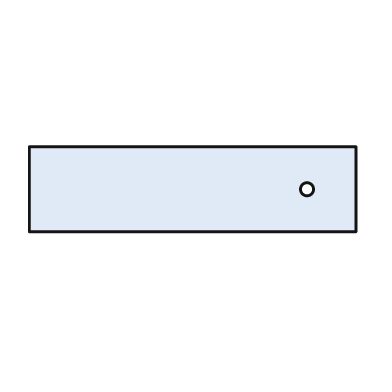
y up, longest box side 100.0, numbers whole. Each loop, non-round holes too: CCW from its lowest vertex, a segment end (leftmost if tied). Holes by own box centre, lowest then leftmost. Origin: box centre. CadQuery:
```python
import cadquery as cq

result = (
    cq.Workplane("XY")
    .moveTo(-50.0, -13.0)
    .lineTo(50.0, -13.0)
    .lineTo(50.0, 13.0)
    .lineTo(-50.0, 13.0)
    .close()
    .moveTo(35.0, 0.0)
    .circle(2.0)
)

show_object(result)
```